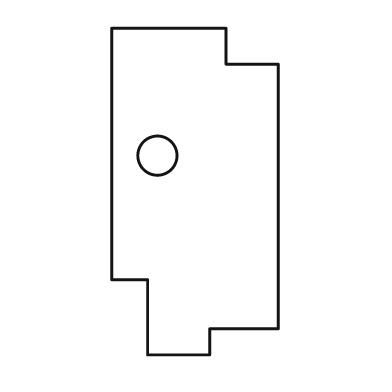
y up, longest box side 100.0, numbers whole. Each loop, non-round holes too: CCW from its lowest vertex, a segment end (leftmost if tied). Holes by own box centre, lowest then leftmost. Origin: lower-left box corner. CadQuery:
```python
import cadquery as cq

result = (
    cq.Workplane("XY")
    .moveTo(11.0, 0.0)
    .lineTo(30.0, 0.0)
    .lineTo(30.0, 8.0)
    .lineTo(51.0, 8.0)
    .lineTo(51.0, 89.0)
    .lineTo(35.0, 89.0)
    .lineTo(35.0, 100.0)
    .lineTo(0.0, 100.0)
    .lineTo(0.0, 23.0)
    .lineTo(11.0, 23.0)
    .close()
    .moveTo(14.0, 61.0)
    .circle(6.0)
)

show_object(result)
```